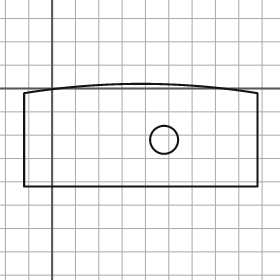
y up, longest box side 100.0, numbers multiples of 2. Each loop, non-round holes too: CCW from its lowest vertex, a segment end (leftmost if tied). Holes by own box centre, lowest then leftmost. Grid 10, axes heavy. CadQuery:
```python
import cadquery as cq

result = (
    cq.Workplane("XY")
    .moveTo(-12.0, -42.0)
    .lineTo(88.0, -42.0)
    .lineTo(88.0, -2.0)
    .threePointArc((38.0, 2.0), (-12.0, -2.0))
    .close()
    .moveTo(48.0, -22.0)
    .circle(6.0)
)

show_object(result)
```